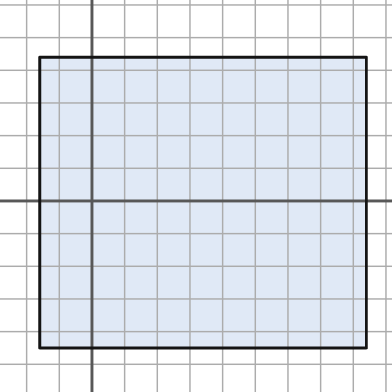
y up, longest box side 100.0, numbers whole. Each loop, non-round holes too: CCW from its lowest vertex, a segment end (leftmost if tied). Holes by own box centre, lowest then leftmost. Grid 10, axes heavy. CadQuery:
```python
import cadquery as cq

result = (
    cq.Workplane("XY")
    .moveTo(-16.0, -45.0)
    .lineTo(84.0, -45.0)
    .lineTo(84.0, 44.0)
    .lineTo(-16.0, 44.0)
    .close()
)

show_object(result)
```